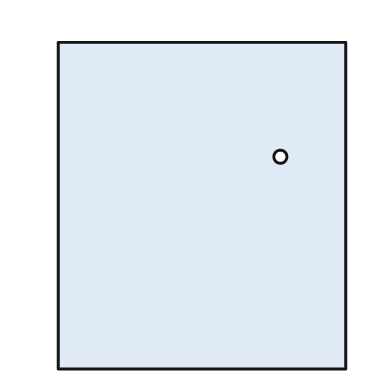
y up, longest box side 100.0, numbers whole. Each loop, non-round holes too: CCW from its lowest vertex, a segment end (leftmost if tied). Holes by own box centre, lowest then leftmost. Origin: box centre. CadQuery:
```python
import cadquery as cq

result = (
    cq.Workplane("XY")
    .moveTo(-44.0, -50.0)
    .lineTo(44.0, -50.0)
    .lineTo(44.0, 50.0)
    .lineTo(-44.0, 50.0)
    .close()
    .moveTo(24.0, 15.0)
    .circle(2.0)
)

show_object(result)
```